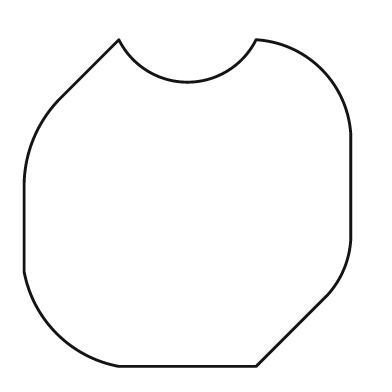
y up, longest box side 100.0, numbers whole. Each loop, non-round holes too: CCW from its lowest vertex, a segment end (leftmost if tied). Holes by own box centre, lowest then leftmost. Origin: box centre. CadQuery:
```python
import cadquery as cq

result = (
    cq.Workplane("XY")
    .moveTo(-21.0, -50.0)
    .lineTo(21.0, -50.0)
    .lineTo(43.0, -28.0)
    .threePointArc((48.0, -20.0), (50.0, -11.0))
    .lineTo(50.0, 21.0)
    .threePointArc((41.0, 41.0), (21.0, 50.0))
    .threePointArc((0.0, 37.0), (-21.0, 50.0))
    .lineTo(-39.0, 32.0)
    .threePointArc((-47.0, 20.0), (-50.0, 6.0))
    .lineTo(-50.0, -21.0)
    .threePointArc((-40.0, -40.0), (-21.0, -50.0))
    .close()
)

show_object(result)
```